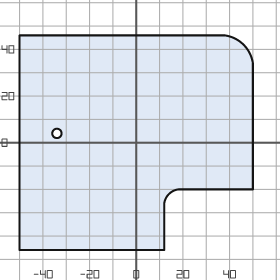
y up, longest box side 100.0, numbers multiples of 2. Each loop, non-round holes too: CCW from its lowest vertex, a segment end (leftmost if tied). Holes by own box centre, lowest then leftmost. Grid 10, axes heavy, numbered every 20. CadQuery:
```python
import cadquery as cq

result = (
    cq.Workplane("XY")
    .moveTo(-50.0, -46.0)
    .lineTo(12.0, -46.0)
    .lineTo(12.0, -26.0)
    .threePointArc((14.0, -22.0), (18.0, -20.0))
    .lineTo(50.0, -20.0)
    .lineTo(50.0, 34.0)
    .threePointArc((46.0, 42.0), (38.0, 46.0))
    .lineTo(-50.0, 46.0)
    .close()
    .moveTo(-34.0, 4.0)
    .circle(2.0)
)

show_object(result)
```